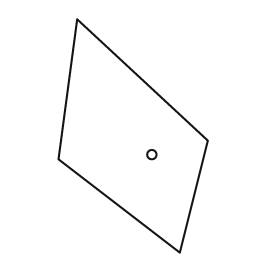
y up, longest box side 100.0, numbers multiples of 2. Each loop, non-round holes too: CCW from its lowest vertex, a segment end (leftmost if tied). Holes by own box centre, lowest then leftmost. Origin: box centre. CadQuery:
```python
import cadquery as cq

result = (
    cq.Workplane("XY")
    .moveTo(20.0, -50.0)
    .lineTo(32.0, -2.0)
    .lineTo(-24.0, 50.0)
    .lineTo(-32.0, -10.0)
    .close()
    .moveTo(8.0, -8.0)
    .circle(2.0)
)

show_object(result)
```